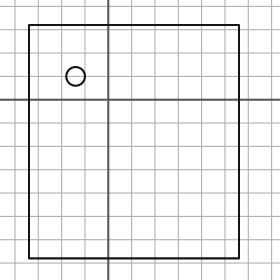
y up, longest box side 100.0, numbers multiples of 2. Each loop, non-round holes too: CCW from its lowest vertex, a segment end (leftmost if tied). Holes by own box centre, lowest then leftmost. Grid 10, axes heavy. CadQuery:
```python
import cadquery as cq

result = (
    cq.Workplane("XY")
    .moveTo(-34.0, -68.0)
    .lineTo(56.0, -68.0)
    .lineTo(56.0, 32.0)
    .lineTo(-34.0, 32.0)
    .close()
    .moveTo(-14.0, 10.0)
    .circle(4.0)
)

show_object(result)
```